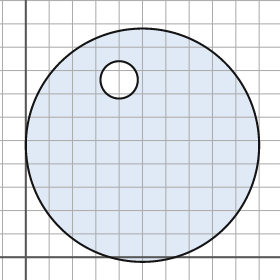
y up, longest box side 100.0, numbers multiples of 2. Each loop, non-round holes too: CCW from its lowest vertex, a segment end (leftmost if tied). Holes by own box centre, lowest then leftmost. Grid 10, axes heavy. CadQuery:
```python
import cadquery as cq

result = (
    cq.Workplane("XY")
    .moveTo(50.0, 48.0)
    .circle(50.0)
    .moveTo(40.0, 76.0)
    .circle(8.0)
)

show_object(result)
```